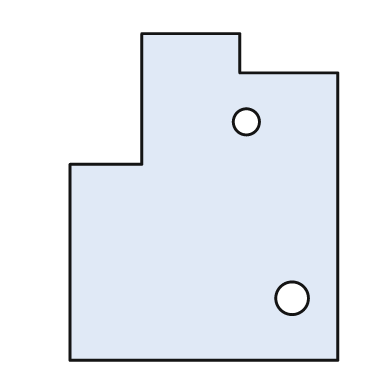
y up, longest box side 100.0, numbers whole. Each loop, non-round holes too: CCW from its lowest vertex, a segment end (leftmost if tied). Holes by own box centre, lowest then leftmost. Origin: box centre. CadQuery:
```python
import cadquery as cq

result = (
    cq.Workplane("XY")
    .moveTo(-41.0, -50.0)
    .lineTo(41.0, -50.0)
    .lineTo(41.0, 38.0)
    .lineTo(11.0, 38.0)
    .lineTo(11.0, 50.0)
    .lineTo(-19.0, 50.0)
    .lineTo(-19.0, 10.0)
    .lineTo(-41.0, 10.0)
    .close()
    .moveTo(27.0, -31.0)
    .circle(5.0)
    .moveTo(13.0, 23.0)
    .circle(4.0)
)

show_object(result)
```